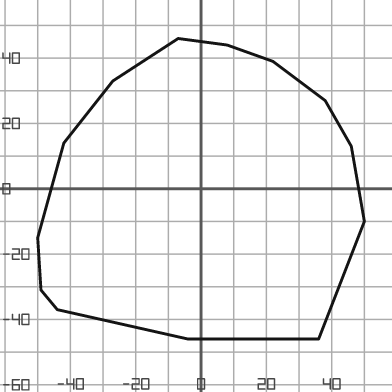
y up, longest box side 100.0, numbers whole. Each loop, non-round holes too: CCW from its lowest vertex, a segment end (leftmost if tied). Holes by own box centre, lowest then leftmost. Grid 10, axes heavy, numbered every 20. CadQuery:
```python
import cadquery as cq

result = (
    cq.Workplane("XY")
    .moveTo(-4.0, -46.0)
    .lineTo(36.0, -46.0)
    .lineTo(50.0, -10.0)
    .lineTo(46.0, 13.0)
    .lineTo(38.0, 27.0)
    .lineTo(22.0, 39.0)
    .lineTo(8.0, 44.0)
    .lineTo(-7.0, 46.0)
    .lineTo(-27.0, 33.0)
    .lineTo(-42.0, 14.0)
    .lineTo(-50.0, -15.0)
    .lineTo(-49.0, -31.0)
    .lineTo(-44.0, -37.0)
    .close()
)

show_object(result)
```